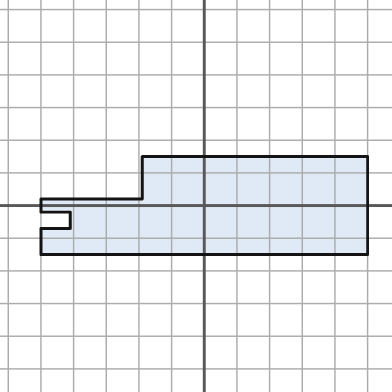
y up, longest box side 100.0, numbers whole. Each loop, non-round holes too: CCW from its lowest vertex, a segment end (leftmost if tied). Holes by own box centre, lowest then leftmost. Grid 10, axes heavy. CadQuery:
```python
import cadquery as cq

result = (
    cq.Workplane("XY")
    .moveTo(-50.0, -15.0)
    .lineTo(50.0, -15.0)
    .lineTo(50.0, 15.0)
    .lineTo(-19.0, 15.0)
    .lineTo(-19.0, 2.0)
    .lineTo(-50.0, 2.0)
    .lineTo(-50.0, -2.0)
    .lineTo(-41.0, -2.0)
    .lineTo(-41.0, -7.0)
    .lineTo(-50.0, -7.0)
    .close()
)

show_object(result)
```